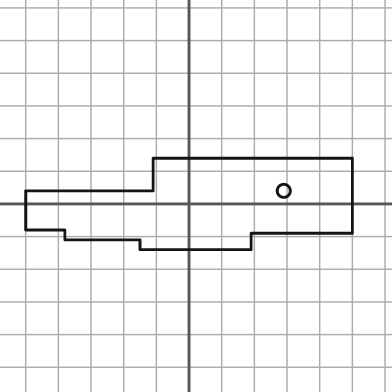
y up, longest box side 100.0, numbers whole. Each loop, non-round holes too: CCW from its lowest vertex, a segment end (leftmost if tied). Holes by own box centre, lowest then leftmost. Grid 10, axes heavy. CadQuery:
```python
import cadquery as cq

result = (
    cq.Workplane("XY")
    .moveTo(-15.0, -14.0)
    .lineTo(19.0, -14.0)
    .lineTo(19.0, -9.0)
    .lineTo(50.0, -9.0)
    .lineTo(50.0, 14.0)
    .lineTo(-11.0, 14.0)
    .lineTo(-11.0, 4.0)
    .lineTo(-50.0, 4.0)
    .lineTo(-50.0, -8.0)
    .lineTo(-38.0, -8.0)
    .lineTo(-38.0, -11.0)
    .lineTo(-15.0, -11.0)
    .close()
    .moveTo(29.0, 4.0)
    .circle(2.0)
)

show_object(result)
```